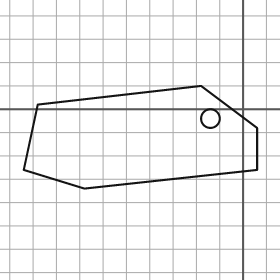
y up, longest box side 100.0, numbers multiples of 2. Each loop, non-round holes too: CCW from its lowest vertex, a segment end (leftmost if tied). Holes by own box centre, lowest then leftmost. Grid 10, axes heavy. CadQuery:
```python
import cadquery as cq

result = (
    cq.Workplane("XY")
    .moveTo(-68.0, -34.0)
    .lineTo(6.0, -26.0)
    .lineTo(6.0, -8.0)
    .lineTo(-18.0, 10.0)
    .lineTo(-88.0, 2.0)
    .lineTo(-94.0, -26.0)
    .close()
    .moveTo(-14.0, -4.0)
    .circle(4.0)
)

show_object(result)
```